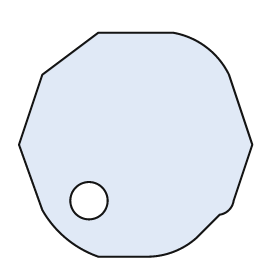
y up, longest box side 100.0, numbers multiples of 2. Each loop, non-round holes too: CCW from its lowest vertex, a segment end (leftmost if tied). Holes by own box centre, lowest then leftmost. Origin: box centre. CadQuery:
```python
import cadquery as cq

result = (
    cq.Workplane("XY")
    .moveTo(-16.0, -48.0)
    .lineTo(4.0, -48.0)
    .threePointArc((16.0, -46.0), (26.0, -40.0))
    .lineTo(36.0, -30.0)
    .threePointArc((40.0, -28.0), (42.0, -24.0))
    .lineTo(50.0, 0.0)
    .lineTo(40.0, 30.0)
    .threePointArc((30.0, 42.0), (16.0, 48.0))
    .lineTo(-16.0, 48.0)
    .lineTo(-40.0, 30.0)
    .lineTo(-50.0, 0.0)
    .lineTo(-40.0, -28.0)
    .threePointArc((-30.0, -40.0), (-16.0, -48.0))
    .close()
    .moveTo(-20.0, -24.0)
    .circle(8.0)
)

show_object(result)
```